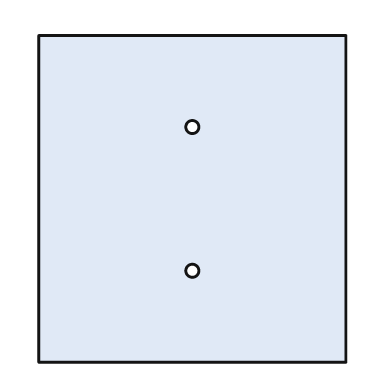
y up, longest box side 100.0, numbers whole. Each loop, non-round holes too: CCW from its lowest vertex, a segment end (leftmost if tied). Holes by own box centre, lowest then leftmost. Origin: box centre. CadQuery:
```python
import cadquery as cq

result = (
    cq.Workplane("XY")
    .moveTo(-47.0, -50.0)
    .lineTo(47.0, -50.0)
    .lineTo(47.0, 50.0)
    .lineTo(-47.0, 50.0)
    .close()
    .moveTo(0.0, -22.0)
    .circle(2.0)
    .moveTo(0.0, 22.0)
    .circle(2.0)
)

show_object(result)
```